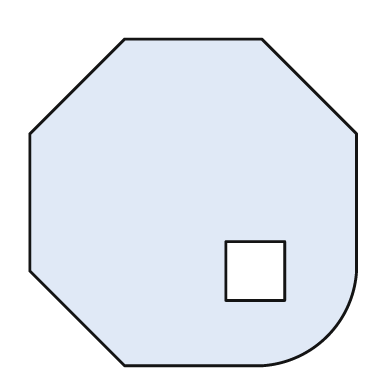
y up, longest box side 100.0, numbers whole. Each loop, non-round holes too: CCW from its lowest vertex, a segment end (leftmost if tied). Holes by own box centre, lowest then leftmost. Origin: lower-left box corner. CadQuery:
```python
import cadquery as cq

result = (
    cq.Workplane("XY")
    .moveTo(29.0, 0.0)
    .lineTo(71.0, 0.0)
    .threePointArc((91.0, 9.0), (100.0, 29.0))
    .lineTo(100.0, 71.0)
    .lineTo(71.0, 100.0)
    .lineTo(29.0, 100.0)
    .lineTo(0.0, 71.0)
    .lineTo(0.0, 29.0)
    .close()
    .moveTo(60.0, 20.0)
    .lineTo(78.0, 20.0)
    .lineTo(78.0, 38.0)
    .lineTo(60.0, 38.0)
    .close()
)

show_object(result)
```